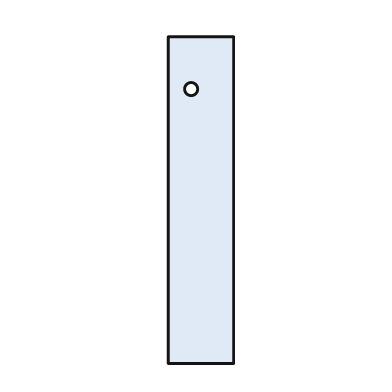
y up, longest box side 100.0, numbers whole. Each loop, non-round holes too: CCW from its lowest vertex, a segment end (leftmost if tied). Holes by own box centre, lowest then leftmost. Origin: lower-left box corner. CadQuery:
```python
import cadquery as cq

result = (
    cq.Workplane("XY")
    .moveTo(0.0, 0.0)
    .lineTo(20.0, 0.0)
    .lineTo(20.0, 100.0)
    .lineTo(0.0, 100.0)
    .close()
    .moveTo(7.0, 84.0)
    .circle(2.0)
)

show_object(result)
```